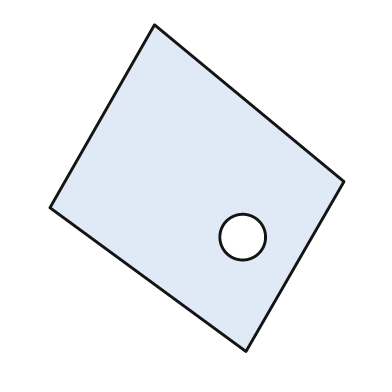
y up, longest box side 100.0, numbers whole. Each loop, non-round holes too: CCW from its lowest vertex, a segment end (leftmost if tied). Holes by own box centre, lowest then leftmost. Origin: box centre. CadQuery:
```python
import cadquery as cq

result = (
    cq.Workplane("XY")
    .moveTo(15.0, -50.0)
    .lineTo(45.0, 2.0)
    .lineTo(-13.0, 50.0)
    .lineTo(-45.0, -6.0)
    .close()
    .moveTo(14.0, -15.0)
    .circle(7.0)
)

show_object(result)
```